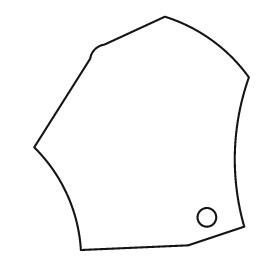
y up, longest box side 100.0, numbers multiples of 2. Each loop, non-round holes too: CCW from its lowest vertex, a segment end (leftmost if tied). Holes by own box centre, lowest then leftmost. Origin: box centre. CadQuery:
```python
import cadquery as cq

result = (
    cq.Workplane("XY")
    .moveTo(-26.0, -50.0)
    .lineTo(20.0, -48.0)
    .lineTo(44.0, -40.0)
    .threePointArc((40.0, -8.0), (46.0, 24.0))
    .threePointArc((30.0, 40.0), (10.0, 50.0))
    .lineTo(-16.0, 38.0)
    .threePointArc((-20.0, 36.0), (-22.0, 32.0))
    .lineTo(-46.0, -6.0)
    .threePointArc((-32.0, -26.0), (-26.0, -50.0))
    .close()
    .moveTo(28.0, -36.0)
    .circle(4.0)
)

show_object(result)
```